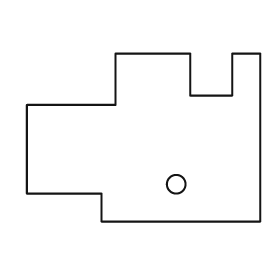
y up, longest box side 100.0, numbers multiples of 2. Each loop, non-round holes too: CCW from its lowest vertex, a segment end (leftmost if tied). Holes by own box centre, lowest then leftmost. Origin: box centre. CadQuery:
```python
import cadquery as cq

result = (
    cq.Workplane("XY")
    .moveTo(-18.0, -36.0)
    .lineTo(50.0, -36.0)
    .lineTo(50.0, 36.0)
    .lineTo(38.0, 36.0)
    .lineTo(38.0, 18.0)
    .lineTo(20.0, 18.0)
    .lineTo(20.0, 36.0)
    .lineTo(-12.0, 36.0)
    .lineTo(-12.0, 14.0)
    .lineTo(-50.0, 14.0)
    .lineTo(-50.0, -24.0)
    .lineTo(-18.0, -24.0)
    .close()
    .moveTo(14.0, -20.0)
    .circle(4.0)
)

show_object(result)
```